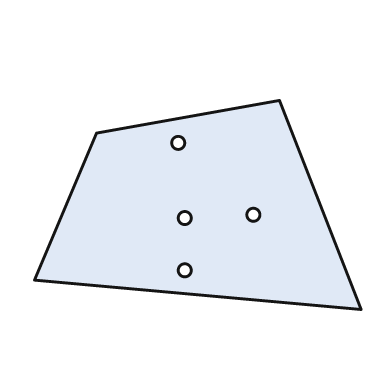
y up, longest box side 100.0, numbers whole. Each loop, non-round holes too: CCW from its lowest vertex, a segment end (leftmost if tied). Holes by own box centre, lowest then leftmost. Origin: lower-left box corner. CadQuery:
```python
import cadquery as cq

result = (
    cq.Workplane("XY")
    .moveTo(100.0, 0.0)
    .lineTo(75.0, 64.0)
    .lineTo(19.0, 54.0)
    .lineTo(0.0, 9.0)
    .close()
    .moveTo(46.0, 12.0)
    .circle(2.0)
    .moveTo(46.0, 28.0)
    .circle(2.0)
    .moveTo(67.0, 29.0)
    .circle(2.0)
    .moveTo(44.0, 51.0)
    .circle(2.0)
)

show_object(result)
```